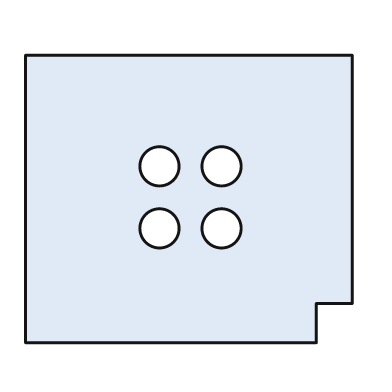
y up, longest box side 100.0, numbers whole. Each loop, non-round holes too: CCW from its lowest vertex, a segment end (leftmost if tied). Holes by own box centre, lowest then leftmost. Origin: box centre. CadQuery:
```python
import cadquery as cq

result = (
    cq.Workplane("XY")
    .moveTo(-50.0, -44.0)
    .lineTo(39.0, -44.0)
    .lineTo(39.0, -32.0)
    .lineTo(50.0, -32.0)
    .lineTo(50.0, 44.0)
    .lineTo(-50.0, 44.0)
    .close()
    .moveTo(-9.0, -9.0)
    .circle(6.0)
    .moveTo(10.0, -9.0)
    .circle(6.0)
    .moveTo(-9.0, 10.0)
    .circle(6.0)
    .moveTo(10.0, 10.0)
    .circle(6.0)
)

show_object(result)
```